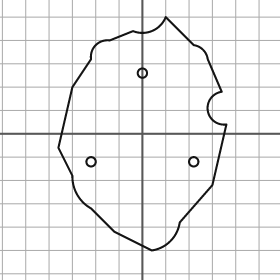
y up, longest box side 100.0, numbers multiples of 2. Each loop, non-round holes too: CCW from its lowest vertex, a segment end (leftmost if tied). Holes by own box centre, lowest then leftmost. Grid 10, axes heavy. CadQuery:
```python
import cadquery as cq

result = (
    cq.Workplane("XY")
    .moveTo(4.0, -50.0)
    .threePointArc((12.0, -46.0), (16.0, -38.0))
    .lineTo(30.0, -22.0)
    .lineTo(36.0, 4.0)
    .threePointArc((28.0, 10.0), (34.0, 18.0))
    .lineTo(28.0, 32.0)
    .threePointArc((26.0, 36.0), (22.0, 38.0))
    .lineTo(10.0, 50.0)
    .threePointArc((4.0, 44.0), (-4.0, 44.0))
    .lineTo(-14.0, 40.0)
    .threePointArc((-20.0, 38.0), (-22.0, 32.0))
    .lineTo(-30.0, 20.0)
    .lineTo(-36.0, -6.0)
    .lineTo(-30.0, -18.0)
    .threePointArc((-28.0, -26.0), (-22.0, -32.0))
    .lineTo(-12.0, -42.0)
    .close()
    .moveTo(-22.0, -12.0)
    .circle(2.0)
    .moveTo(22.0, -12.0)
    .circle(2.0)
    .moveTo(0.0, 26.0)
    .circle(2.0)
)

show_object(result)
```